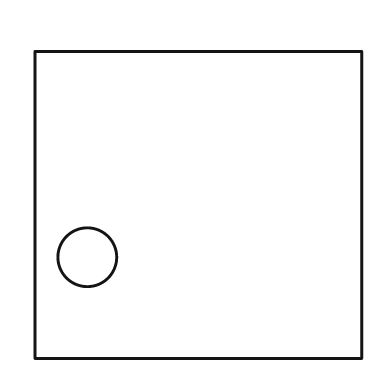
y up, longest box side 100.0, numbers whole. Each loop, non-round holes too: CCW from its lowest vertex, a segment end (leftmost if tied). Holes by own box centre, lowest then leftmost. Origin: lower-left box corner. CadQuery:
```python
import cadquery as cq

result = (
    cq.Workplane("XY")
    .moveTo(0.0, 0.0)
    .lineTo(100.0, 0.0)
    .lineTo(100.0, 94.0)
    .lineTo(0.0, 94.0)
    .close()
    .moveTo(16.0, 31.0)
    .circle(9.0)
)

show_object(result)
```